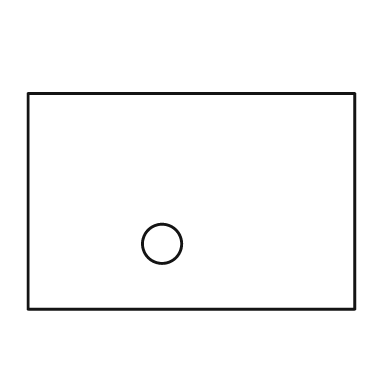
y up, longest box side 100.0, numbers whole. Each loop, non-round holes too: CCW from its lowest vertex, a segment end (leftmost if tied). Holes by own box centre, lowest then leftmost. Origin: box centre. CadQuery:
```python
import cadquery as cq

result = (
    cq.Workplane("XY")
    .moveTo(-50.0, -33.0)
    .lineTo(50.0, -33.0)
    .lineTo(50.0, 33.0)
    .lineTo(-50.0, 33.0)
    .close()
    .moveTo(-9.0, -13.0)
    .circle(6.0)
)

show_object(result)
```